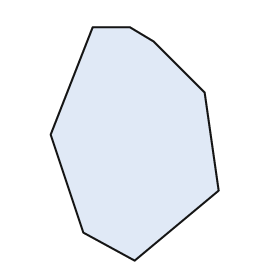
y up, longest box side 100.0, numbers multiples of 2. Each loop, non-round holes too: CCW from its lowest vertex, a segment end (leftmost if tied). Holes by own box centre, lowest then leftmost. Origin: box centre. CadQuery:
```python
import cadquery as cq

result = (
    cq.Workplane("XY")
    .moveTo(0.0, -50.0)
    .lineTo(36.0, -20.0)
    .lineTo(30.0, 22.0)
    .lineTo(8.0, 44.0)
    .lineTo(-2.0, 50.0)
    .lineTo(-18.0, 50.0)
    .lineTo(-36.0, 4.0)
    .lineTo(-22.0, -38.0)
    .close()
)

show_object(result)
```